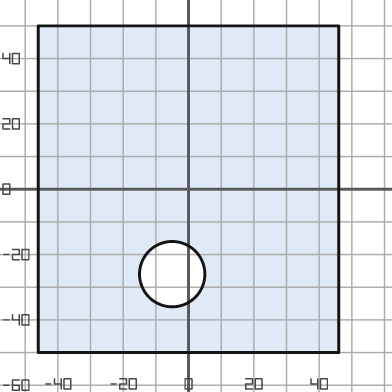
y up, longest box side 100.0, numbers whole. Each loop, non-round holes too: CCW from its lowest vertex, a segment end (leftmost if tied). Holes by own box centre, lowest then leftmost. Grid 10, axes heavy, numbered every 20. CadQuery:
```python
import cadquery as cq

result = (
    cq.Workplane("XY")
    .moveTo(-46.0, -50.0)
    .lineTo(46.0, -50.0)
    .lineTo(46.0, 50.0)
    .lineTo(-46.0, 50.0)
    .close()
    .moveTo(-5.0, -26.0)
    .circle(10.0)
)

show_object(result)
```